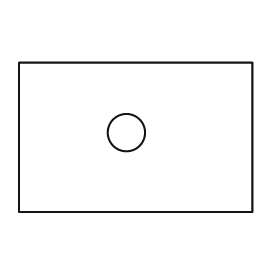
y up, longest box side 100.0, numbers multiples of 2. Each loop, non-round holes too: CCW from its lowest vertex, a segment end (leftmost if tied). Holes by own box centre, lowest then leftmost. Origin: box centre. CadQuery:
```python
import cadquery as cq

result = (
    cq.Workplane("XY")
    .moveTo(-50.0, -32.0)
    .lineTo(50.0, -32.0)
    .lineTo(50.0, 32.0)
    .lineTo(-50.0, 32.0)
    .close()
    .moveTo(-4.0, 2.0)
    .circle(8.0)
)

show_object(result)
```